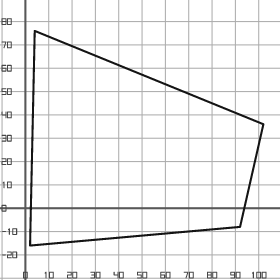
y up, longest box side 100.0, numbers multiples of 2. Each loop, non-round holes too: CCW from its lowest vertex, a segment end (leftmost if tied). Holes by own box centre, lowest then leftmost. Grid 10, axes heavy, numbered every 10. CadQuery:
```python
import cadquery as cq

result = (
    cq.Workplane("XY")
    .moveTo(2.0, -16.0)
    .lineTo(92.0, -8.0)
    .lineTo(102.0, 36.0)
    .lineTo(4.0, 76.0)
    .close()
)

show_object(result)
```